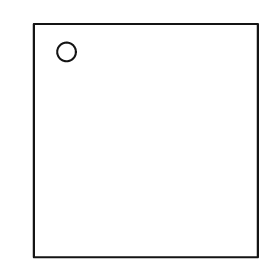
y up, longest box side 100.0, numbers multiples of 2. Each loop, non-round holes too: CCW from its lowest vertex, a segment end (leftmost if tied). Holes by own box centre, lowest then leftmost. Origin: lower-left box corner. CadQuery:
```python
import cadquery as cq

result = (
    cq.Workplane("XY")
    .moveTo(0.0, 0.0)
    .lineTo(96.0, 0.0)
    .lineTo(96.0, 100.0)
    .lineTo(0.0, 100.0)
    .close()
    .moveTo(14.0, 88.0)
    .circle(4.0)
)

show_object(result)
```